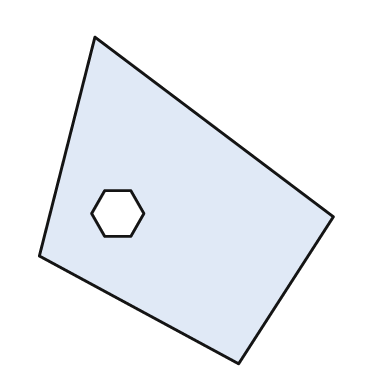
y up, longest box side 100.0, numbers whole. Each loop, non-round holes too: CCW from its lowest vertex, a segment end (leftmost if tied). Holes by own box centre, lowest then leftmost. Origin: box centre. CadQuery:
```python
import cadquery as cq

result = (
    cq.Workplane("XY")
    .moveTo(16.0, -50.0)
    .lineTo(45.0, -5.0)
    .lineTo(-28.0, 50.0)
    .lineTo(-45.0, -17.0)
    .close()
    .moveTo(-25.0, -11.0)
    .lineTo(-17.0, -11.0)
    .lineTo(-13.0, -4.0)
    .lineTo(-17.0, 3.0)
    .lineTo(-25.0, 3.0)
    .lineTo(-29.0, -4.0)
    .close()
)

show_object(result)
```